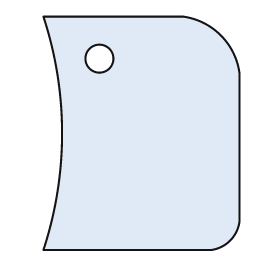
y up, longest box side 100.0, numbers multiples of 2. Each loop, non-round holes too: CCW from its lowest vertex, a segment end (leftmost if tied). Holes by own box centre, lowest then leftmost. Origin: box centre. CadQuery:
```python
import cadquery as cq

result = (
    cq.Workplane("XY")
    .moveTo(-42.0, -50.0)
    .lineTo(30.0, -50.0)
    .threePointArc((38.0, -46.0), (42.0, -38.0))
    .lineTo(42.0, 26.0)
    .threePointArc((34.0, 42.0), (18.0, 50.0))
    .lineTo(-42.0, 50.0)
    .threePointArc((-34.0, 0.0), (-42.0, -50.0))
    .close()
    .moveTo(-18.0, 32.0)
    .circle(6.0)
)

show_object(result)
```